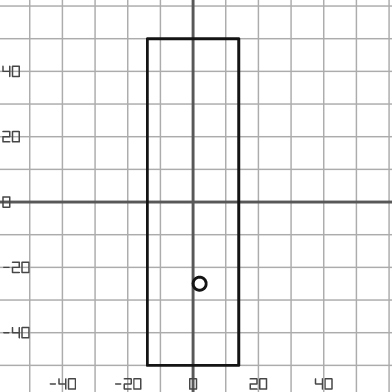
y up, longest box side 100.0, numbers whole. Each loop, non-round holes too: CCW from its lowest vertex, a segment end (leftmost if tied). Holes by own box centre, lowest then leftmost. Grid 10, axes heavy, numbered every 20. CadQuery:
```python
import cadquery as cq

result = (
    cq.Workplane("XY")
    .moveTo(-14.0, -50.0)
    .lineTo(14.0, -50.0)
    .lineTo(14.0, 50.0)
    .lineTo(-14.0, 50.0)
    .close()
    .moveTo(2.0, -25.0)
    .circle(2.0)
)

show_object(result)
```